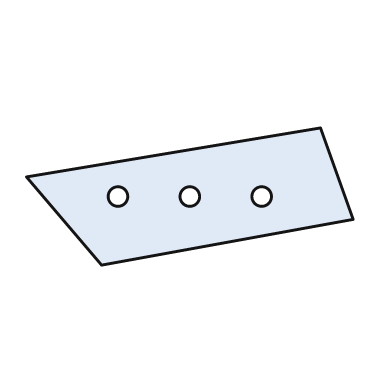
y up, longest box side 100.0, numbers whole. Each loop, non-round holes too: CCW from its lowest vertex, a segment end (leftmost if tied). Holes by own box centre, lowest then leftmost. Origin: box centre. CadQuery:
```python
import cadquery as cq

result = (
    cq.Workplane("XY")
    .moveTo(-27.0, -21.0)
    .lineTo(50.0, -7.0)
    .lineTo(40.0, 21.0)
    .lineTo(-50.0, 6.0)
    .close()
    .moveTo(-22.0, 0.0)
    .circle(3.0)
    .moveTo(0.0, 0.0)
    .circle(3.0)
    .moveTo(22.0, 0.0)
    .circle(3.0)
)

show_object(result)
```